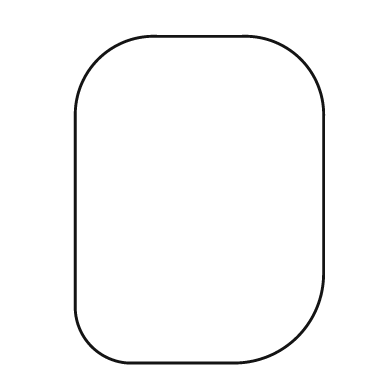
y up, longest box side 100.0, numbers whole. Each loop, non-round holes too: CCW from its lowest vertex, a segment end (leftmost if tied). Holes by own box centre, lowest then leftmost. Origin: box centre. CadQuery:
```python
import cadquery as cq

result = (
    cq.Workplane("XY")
    .moveTo(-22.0, -50.0)
    .lineTo(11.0, -50.0)
    .threePointArc((30.0, -42.0), (38.0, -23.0))
    .lineTo(38.0, 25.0)
    .threePointArc((31.0, 43.0), (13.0, 50.0))
    .lineTo(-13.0, 50.0)
    .threePointArc((-31.0, 43.0), (-38.0, 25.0))
    .lineTo(-38.0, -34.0)
    .threePointArc((-33.0, -45.0), (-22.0, -50.0))
    .close()
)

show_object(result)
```